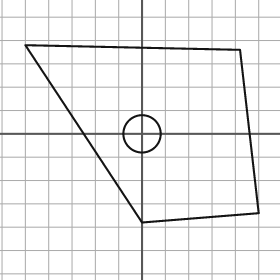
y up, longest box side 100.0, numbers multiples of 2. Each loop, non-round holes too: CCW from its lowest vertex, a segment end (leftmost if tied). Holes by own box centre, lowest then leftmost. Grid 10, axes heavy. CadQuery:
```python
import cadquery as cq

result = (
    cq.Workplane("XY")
    .moveTo(0.0, -38.0)
    .lineTo(50.0, -34.0)
    .lineTo(42.0, 36.0)
    .lineTo(-50.0, 38.0)
    .close()
    .moveTo(0.0, 0.0)
    .circle(8.0)
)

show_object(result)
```